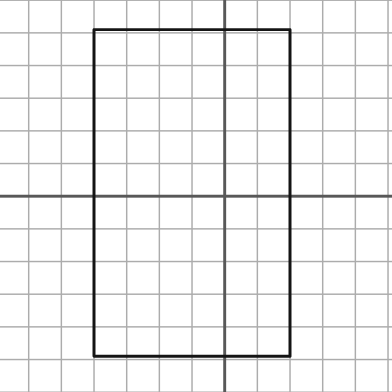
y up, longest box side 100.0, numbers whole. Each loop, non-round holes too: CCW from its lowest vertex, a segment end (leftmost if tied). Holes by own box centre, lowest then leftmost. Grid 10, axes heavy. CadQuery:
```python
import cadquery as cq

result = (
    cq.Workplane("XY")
    .moveTo(-40.0, -49.0)
    .lineTo(20.0, -49.0)
    .lineTo(20.0, 51.0)
    .lineTo(-40.0, 51.0)
    .close()
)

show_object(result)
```